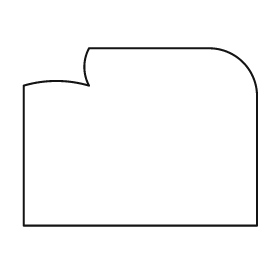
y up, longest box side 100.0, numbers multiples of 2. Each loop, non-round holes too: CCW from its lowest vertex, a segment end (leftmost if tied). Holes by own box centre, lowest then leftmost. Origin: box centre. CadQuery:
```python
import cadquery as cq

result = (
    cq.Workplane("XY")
    .moveTo(-50.0, -38.0)
    .lineTo(50.0, -38.0)
    .lineTo(50.0, 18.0)
    .threePointArc((44.0, 32.0), (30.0, 38.0))
    .lineTo(-22.0, 38.0)
    .threePointArc((-24.0, 30.0), (-22.0, 22.0))
    .threePointArc((-36.0, 24.0), (-50.0, 22.0))
    .close()
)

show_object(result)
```